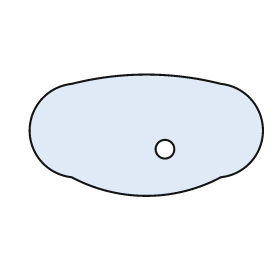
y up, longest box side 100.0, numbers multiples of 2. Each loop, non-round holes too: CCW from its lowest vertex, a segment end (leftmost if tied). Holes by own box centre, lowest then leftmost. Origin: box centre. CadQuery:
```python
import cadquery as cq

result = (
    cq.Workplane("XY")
    .moveTo(-32.0, -18.0)
    .threePointArc((0.0, -26.0), (32.0, -18.0))
    .threePointArc((50.0, 2.0), (32.0, 22.0))
    .threePointArc((0.0, 26.0), (-32.0, 22.0))
    .threePointArc((-50.0, 2.0), (-32.0, -18.0))
    .close()
    .moveTo(8.0, -6.0)
    .circle(4.0)
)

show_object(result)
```